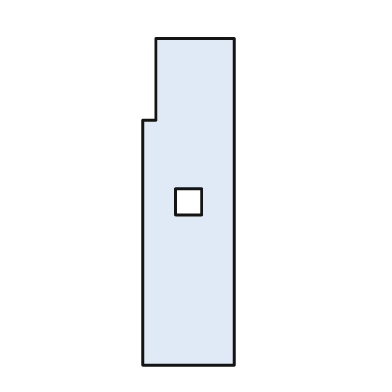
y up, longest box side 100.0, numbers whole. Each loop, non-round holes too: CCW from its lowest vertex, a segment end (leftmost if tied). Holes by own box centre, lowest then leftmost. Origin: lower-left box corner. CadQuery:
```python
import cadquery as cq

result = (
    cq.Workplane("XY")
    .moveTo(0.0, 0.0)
    .lineTo(28.0, 0.0)
    .lineTo(28.0, 100.0)
    .lineTo(4.0, 100.0)
    .lineTo(4.0, 75.0)
    .lineTo(0.0, 75.0)
    .close()
    .moveTo(10.0, 46.0)
    .lineTo(18.0, 46.0)
    .lineTo(18.0, 54.0)
    .lineTo(10.0, 54.0)
    .close()
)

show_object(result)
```